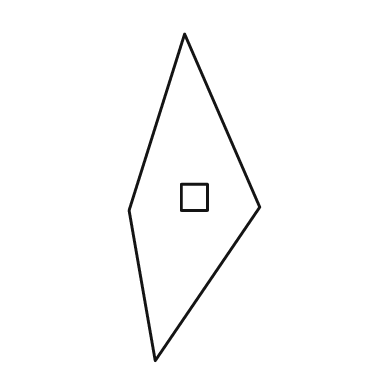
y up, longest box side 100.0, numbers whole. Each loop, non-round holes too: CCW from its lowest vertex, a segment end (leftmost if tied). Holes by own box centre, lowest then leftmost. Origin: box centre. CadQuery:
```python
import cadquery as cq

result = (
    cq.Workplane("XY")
    .moveTo(-12.0, -50.0)
    .lineTo(20.0, -3.0)
    .lineTo(-3.0, 50.0)
    .lineTo(-20.0, -4.0)
    .close()
    .moveTo(-4.0, -4.0)
    .lineTo(4.0, -4.0)
    .lineTo(4.0, 4.0)
    .lineTo(-4.0, 4.0)
    .close()
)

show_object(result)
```